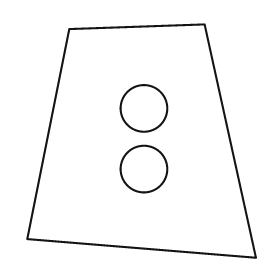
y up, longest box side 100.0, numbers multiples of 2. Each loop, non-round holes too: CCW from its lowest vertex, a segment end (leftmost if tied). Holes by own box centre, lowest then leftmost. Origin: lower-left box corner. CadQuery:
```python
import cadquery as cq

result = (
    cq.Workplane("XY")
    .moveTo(98.0, 0.0)
    .lineTo(76.0, 100.0)
    .lineTo(18.0, 98.0)
    .lineTo(0.0, 8.0)
    .close()
    .moveTo(50.0, 38.0)
    .circle(10.0)
    .moveTo(50.0, 64.0)
    .circle(10.0)
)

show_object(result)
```